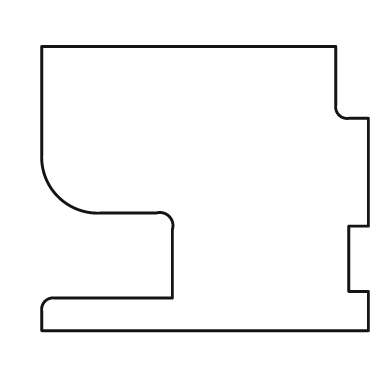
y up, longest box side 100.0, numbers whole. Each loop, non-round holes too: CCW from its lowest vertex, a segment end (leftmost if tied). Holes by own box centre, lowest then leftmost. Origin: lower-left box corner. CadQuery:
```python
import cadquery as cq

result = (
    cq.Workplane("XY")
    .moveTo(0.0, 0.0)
    .lineTo(100.0, 0.0)
    .lineTo(100.0, 12.0)
    .lineTo(94.0, 12.0)
    .lineTo(94.0, 32.0)
    .lineTo(100.0, 32.0)
    .lineTo(100.0, 65.0)
    .lineTo(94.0, 65.0)
    .threePointArc((91.0, 66.0), (90.0, 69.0))
    .lineTo(90.0, 87.0)
    .lineTo(0.0, 87.0)
    .lineTo(0.0, 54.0)
    .threePointArc((5.0, 41.0), (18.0, 36.0))
    .lineTo(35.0, 36.0)
    .threePointArc((39.0, 35.0), (40.0, 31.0))
    .lineTo(40.0, 10.0)
    .lineTo(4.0, 10.0)
    .threePointArc((1.0, 9.0), (0.0, 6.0))
    .close()
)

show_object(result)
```